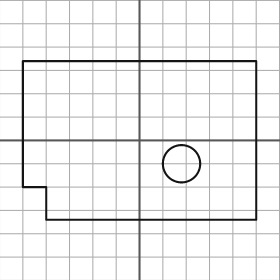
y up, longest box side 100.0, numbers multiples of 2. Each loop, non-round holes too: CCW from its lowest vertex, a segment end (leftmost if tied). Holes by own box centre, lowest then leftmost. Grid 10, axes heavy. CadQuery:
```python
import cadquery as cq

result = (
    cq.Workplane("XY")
    .moveTo(-40.0, -34.0)
    .lineTo(50.0, -34.0)
    .lineTo(50.0, 34.0)
    .lineTo(-50.0, 34.0)
    .lineTo(-50.0, -20.0)
    .lineTo(-40.0, -20.0)
    .close()
    .moveTo(18.0, -10.0)
    .circle(8.0)
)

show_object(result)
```